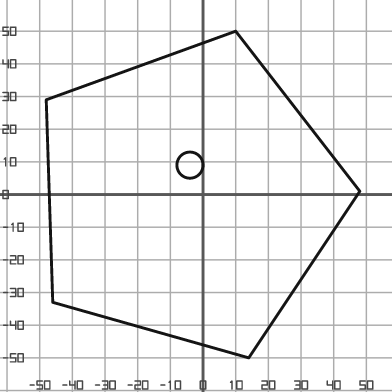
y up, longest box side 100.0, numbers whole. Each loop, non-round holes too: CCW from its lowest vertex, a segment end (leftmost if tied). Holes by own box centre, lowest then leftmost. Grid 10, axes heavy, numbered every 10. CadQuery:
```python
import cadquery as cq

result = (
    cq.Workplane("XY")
    .moveTo(14.0, -50.0)
    .lineTo(48.0, 1.0)
    .lineTo(10.0, 50.0)
    .lineTo(-48.0, 29.0)
    .lineTo(-46.0, -33.0)
    .close()
    .moveTo(-4.0, 9.0)
    .circle(4.0)
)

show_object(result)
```